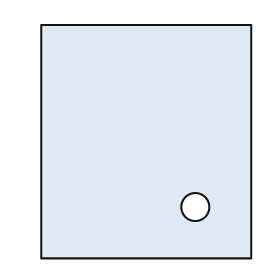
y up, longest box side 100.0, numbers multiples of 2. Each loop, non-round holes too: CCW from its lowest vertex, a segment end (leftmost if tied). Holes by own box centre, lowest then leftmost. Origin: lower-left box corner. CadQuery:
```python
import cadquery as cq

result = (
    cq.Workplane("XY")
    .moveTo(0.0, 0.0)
    .lineTo(90.0, 0.0)
    .lineTo(90.0, 100.0)
    .lineTo(0.0, 100.0)
    .close()
    .moveTo(66.0, 22.0)
    .circle(6.0)
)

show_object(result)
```